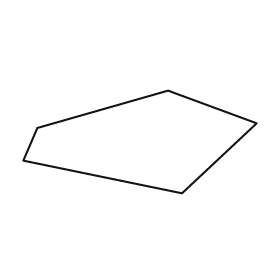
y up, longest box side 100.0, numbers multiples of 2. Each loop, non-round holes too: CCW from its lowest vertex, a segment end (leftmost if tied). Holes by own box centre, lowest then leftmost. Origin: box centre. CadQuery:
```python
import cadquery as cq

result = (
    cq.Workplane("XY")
    .moveTo(18.0, -22.0)
    .lineTo(50.0, 8.0)
    .lineTo(12.0, 22.0)
    .lineTo(-44.0, 6.0)
    .lineTo(-50.0, -8.0)
    .close()
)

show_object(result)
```